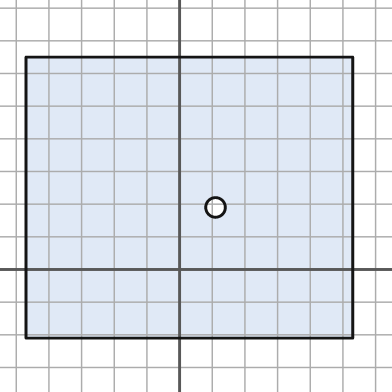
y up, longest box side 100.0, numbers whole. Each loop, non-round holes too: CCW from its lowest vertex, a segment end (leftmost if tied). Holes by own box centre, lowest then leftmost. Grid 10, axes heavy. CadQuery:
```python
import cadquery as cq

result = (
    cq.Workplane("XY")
    .moveTo(-47.0, -21.0)
    .lineTo(53.0, -21.0)
    .lineTo(53.0, 65.0)
    .lineTo(-47.0, 65.0)
    .close()
    .moveTo(11.0, 19.0)
    .circle(3.0)
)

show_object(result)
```